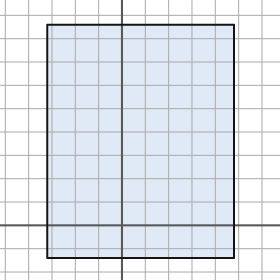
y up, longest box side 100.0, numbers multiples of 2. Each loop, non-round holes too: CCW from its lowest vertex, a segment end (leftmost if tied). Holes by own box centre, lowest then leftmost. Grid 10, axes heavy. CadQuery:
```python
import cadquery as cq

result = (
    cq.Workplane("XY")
    .moveTo(-32.0, -14.0)
    .lineTo(48.0, -14.0)
    .lineTo(48.0, 86.0)
    .lineTo(-32.0, 86.0)
    .close()
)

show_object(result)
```